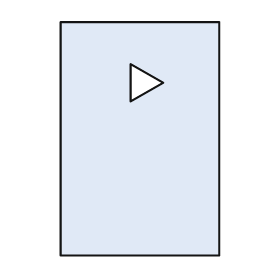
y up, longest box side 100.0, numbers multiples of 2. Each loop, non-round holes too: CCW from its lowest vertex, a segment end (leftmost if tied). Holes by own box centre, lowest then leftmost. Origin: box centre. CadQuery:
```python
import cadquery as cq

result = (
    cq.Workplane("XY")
    .moveTo(-34.0, -50.0)
    .lineTo(34.0, -50.0)
    .lineTo(34.0, 50.0)
    .lineTo(-34.0, 50.0)
    .close()
    .moveTo(-4.0, 16.0)
    .lineTo(10.0, 24.0)
    .lineTo(-4.0, 32.0)
    .close()
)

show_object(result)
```